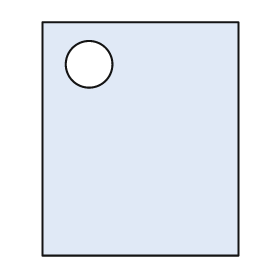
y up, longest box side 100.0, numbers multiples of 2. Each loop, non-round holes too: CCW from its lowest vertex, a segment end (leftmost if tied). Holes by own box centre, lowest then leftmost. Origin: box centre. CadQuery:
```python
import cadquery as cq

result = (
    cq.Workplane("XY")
    .moveTo(-42.0, -50.0)
    .lineTo(42.0, -50.0)
    .lineTo(42.0, 50.0)
    .lineTo(-42.0, 50.0)
    .close()
    .moveTo(-22.0, 32.0)
    .circle(10.0)
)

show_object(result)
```